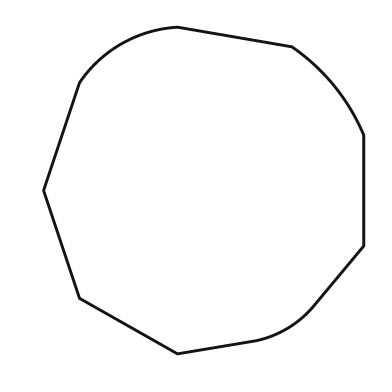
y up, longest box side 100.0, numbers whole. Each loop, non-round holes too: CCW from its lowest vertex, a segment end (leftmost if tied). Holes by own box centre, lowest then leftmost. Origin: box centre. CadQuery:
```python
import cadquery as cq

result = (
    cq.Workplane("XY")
    .moveTo(-8.0, -50.0)
    .lineTo(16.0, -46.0)
    .threePointArc((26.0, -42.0), (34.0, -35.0))
    .lineTo(49.0, -17.0)
    .lineTo(49.0, 17.0)
    .threePointArc((40.0, 32.0), (27.0, 44.0))
    .lineTo(-8.0, 50.0)
    .threePointArc((-25.0, 45.0), (-38.0, 33.0))
    .lineTo(-49.0, 0.0)
    .lineTo(-38.0, -33.0)
    .close()
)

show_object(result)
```